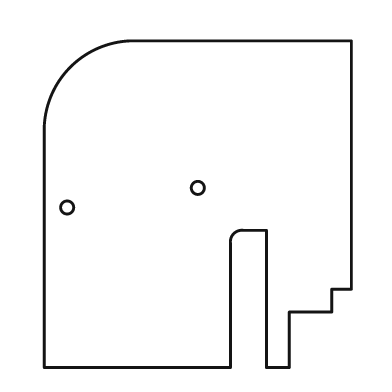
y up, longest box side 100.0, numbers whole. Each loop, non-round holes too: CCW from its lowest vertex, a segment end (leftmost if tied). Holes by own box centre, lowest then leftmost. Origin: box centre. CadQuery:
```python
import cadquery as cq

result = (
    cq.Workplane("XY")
    .moveTo(-47.0, -50.0)
    .lineTo(10.0, -50.0)
    .lineTo(10.0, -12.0)
    .threePointArc((11.0, -9.0), (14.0, -8.0))
    .lineTo(21.0, -8.0)
    .lineTo(21.0, -50.0)
    .lineTo(28.0, -50.0)
    .lineTo(28.0, -33.0)
    .lineTo(41.0, -33.0)
    .lineTo(41.0, -26.0)
    .lineTo(47.0, -26.0)
    .lineTo(47.0, 50.0)
    .lineTo(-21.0, 50.0)
    .threePointArc((-39.0, 42.0), (-47.0, 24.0))
    .close()
    .moveTo(-40.0, -1.0)
    .circle(2.0)
    .moveTo(0.0, 5.0)
    .circle(2.0)
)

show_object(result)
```